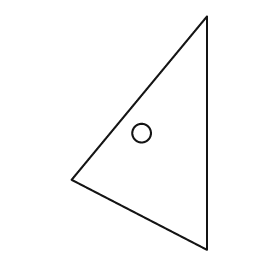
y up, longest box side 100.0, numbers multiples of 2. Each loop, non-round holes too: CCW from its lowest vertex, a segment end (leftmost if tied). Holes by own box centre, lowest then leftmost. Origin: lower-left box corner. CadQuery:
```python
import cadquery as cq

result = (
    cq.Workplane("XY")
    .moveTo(58.0, 0.0)
    .lineTo(58.0, 100.0)
    .lineTo(0.0, 30.0)
    .close()
    .moveTo(30.0, 50.0)
    .circle(4.0)
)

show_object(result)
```